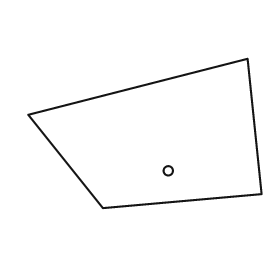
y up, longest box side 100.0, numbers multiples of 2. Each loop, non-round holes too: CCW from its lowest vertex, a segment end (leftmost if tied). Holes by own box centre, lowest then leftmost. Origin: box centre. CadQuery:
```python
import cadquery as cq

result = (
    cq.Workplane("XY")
    .moveTo(-18.0, -32.0)
    .lineTo(50.0, -26.0)
    .lineTo(44.0, 32.0)
    .lineTo(-50.0, 8.0)
    .close()
    .moveTo(10.0, -16.0)
    .circle(2.0)
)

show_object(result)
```